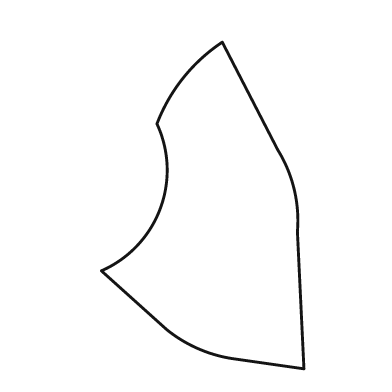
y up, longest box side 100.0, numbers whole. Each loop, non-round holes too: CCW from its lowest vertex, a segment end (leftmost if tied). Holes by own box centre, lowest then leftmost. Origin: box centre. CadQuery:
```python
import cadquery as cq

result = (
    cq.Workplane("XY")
    .moveTo(31.0, -50.0)
    .lineTo(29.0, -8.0)
    .threePointArc((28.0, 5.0), (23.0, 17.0))
    .lineTo(6.0, 50.0)
    .threePointArc((-6.0, 39.0), (-14.0, 25.0))
    .threePointArc((-13.0, -1.0), (-31.0, -20.0))
    .lineTo(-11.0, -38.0)
    .threePointArc((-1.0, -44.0), (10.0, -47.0))
    .close()
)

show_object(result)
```